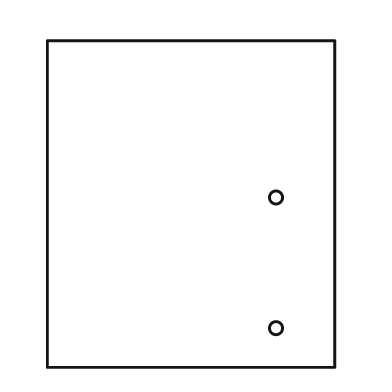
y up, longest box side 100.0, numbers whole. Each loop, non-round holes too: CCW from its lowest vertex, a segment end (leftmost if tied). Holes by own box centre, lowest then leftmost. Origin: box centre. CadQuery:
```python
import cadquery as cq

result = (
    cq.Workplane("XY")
    .moveTo(-44.0, -50.0)
    .lineTo(44.0, -50.0)
    .lineTo(44.0, 50.0)
    .lineTo(-44.0, 50.0)
    .close()
    .moveTo(26.0, -38.0)
    .circle(2.0)
    .moveTo(26.0, 2.0)
    .circle(2.0)
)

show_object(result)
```